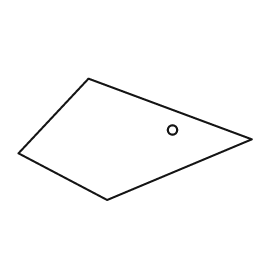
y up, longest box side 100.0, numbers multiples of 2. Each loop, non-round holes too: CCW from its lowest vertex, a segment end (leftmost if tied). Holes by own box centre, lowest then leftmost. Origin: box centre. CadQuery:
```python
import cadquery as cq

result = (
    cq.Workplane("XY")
    .moveTo(-12.0, -26.0)
    .lineTo(50.0, 0.0)
    .lineTo(-20.0, 26.0)
    .lineTo(-50.0, -6.0)
    .close()
    .moveTo(16.0, 4.0)
    .circle(2.0)
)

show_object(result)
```